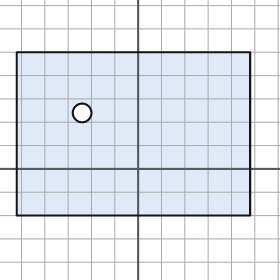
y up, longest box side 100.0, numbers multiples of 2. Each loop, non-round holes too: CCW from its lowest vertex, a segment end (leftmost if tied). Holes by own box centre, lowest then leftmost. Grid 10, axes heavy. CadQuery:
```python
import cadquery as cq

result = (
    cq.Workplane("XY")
    .moveTo(-52.0, -20.0)
    .lineTo(48.0, -20.0)
    .lineTo(48.0, 50.0)
    .lineTo(-52.0, 50.0)
    .close()
    .moveTo(-24.0, 24.0)
    .circle(4.0)
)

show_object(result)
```